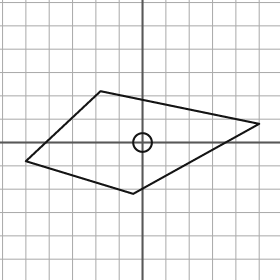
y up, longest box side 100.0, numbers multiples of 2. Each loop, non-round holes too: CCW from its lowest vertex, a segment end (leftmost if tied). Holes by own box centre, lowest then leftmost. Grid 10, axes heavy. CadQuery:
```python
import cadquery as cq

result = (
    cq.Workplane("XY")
    .moveTo(-4.0, -22.0)
    .lineTo(50.0, 8.0)
    .lineTo(-18.0, 22.0)
    .lineTo(-50.0, -8.0)
    .close()
    .moveTo(0.0, 0.0)
    .circle(4.0)
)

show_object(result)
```